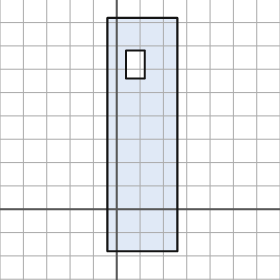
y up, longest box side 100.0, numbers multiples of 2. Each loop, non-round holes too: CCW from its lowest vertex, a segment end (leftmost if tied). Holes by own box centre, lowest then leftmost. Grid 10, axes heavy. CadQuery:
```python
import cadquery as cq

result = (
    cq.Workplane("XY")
    .moveTo(-4.0, -18.0)
    .lineTo(26.0, -18.0)
    .lineTo(26.0, 82.0)
    .lineTo(-4.0, 82.0)
    .close()
    .moveTo(4.0, 56.0)
    .lineTo(12.0, 56.0)
    .lineTo(12.0, 68.0)
    .lineTo(4.0, 68.0)
    .close()
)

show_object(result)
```